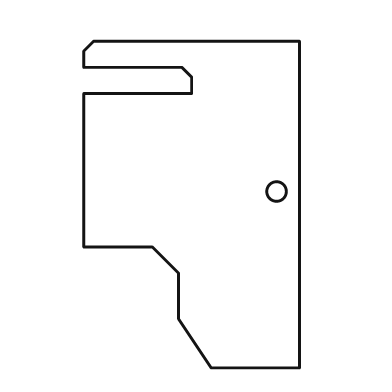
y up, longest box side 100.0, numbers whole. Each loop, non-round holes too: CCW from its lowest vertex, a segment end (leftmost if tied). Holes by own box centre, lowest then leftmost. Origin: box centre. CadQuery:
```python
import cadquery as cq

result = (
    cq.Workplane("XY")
    .moveTo(6.0, -50.0)
    .lineTo(33.0, -50.0)
    .lineTo(33.0, 50.0)
    .lineTo(-30.0, 50.0)
    .lineTo(-33.0, 47.0)
    .lineTo(-33.0, 42.0)
    .lineTo(-3.0, 42.0)
    .lineTo(0.0, 39.0)
    .lineTo(0.0, 34.0)
    .lineTo(-33.0, 34.0)
    .lineTo(-33.0, -13.0)
    .lineTo(-12.0, -13.0)
    .lineTo(-4.0, -21.0)
    .lineTo(-4.0, -35.0)
    .close()
    .moveTo(26.0, 4.0)
    .circle(3.0)
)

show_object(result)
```